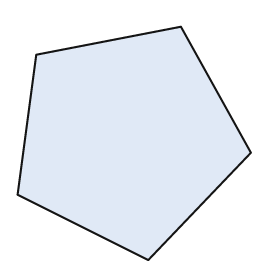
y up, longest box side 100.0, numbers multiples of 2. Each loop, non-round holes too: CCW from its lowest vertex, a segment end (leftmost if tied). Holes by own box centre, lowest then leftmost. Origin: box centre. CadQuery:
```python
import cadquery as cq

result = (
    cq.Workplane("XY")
    .moveTo(6.0, -50.0)
    .lineTo(50.0, -4.0)
    .lineTo(20.0, 50.0)
    .lineTo(-42.0, 38.0)
    .lineTo(-50.0, -22.0)
    .close()
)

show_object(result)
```